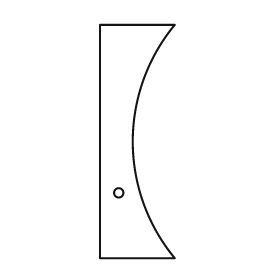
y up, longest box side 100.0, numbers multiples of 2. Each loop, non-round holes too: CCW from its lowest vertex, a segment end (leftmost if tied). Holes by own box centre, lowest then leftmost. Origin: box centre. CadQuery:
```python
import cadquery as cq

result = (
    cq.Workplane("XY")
    .moveTo(-16.0, -50.0)
    .lineTo(16.0, -50.0)
    .threePointArc((-2.0, 0.0), (16.0, 50.0))
    .lineTo(-16.0, 50.0)
    .close()
    .moveTo(-8.0, -22.0)
    .circle(2.0)
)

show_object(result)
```